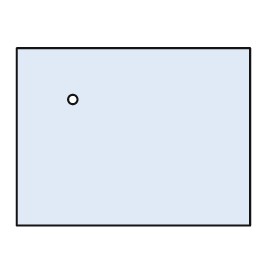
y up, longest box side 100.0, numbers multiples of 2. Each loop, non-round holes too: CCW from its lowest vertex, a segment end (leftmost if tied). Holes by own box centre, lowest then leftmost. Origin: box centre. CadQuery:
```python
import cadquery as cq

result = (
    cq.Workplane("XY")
    .moveTo(-50.0, -38.0)
    .lineTo(50.0, -38.0)
    .lineTo(50.0, 38.0)
    .lineTo(-50.0, 38.0)
    .close()
    .moveTo(-26.0, 16.0)
    .circle(2.0)
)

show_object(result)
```